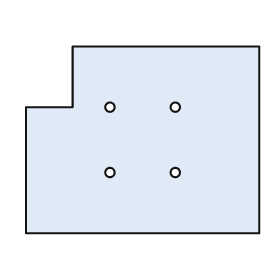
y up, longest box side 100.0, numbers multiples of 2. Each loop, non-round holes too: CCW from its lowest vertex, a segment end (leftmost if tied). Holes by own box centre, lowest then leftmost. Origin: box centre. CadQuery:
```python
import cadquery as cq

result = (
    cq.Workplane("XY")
    .moveTo(-50.0, -40.0)
    .lineTo(50.0, -40.0)
    .lineTo(50.0, 40.0)
    .lineTo(-30.0, 40.0)
    .lineTo(-30.0, 14.0)
    .lineTo(-50.0, 14.0)
    .close()
    .moveTo(-14.0, -14.0)
    .circle(2.0)
    .moveTo(14.0, -14.0)
    .circle(2.0)
    .moveTo(-14.0, 14.0)
    .circle(2.0)
    .moveTo(14.0, 14.0)
    .circle(2.0)
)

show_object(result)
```